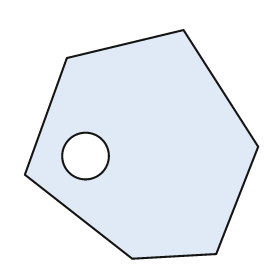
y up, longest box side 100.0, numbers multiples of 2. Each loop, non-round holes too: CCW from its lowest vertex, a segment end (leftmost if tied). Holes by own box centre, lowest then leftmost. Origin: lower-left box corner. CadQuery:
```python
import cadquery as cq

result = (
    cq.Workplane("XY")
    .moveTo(46.0, 0.0)
    .lineTo(82.0, 2.0)
    .lineTo(100.0, 48.0)
    .lineTo(68.0, 98.0)
    .lineTo(18.0, 86.0)
    .lineTo(0.0, 36.0)
    .close()
    .moveTo(26.0, 44.0)
    .circle(10.0)
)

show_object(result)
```